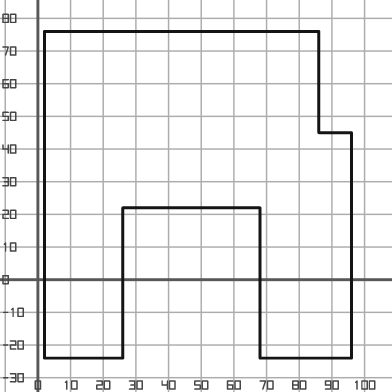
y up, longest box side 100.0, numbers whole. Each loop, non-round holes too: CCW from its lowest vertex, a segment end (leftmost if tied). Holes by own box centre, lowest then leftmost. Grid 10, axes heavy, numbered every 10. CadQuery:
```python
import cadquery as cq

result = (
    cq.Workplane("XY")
    .moveTo(2.0, -24.0)
    .lineTo(26.0, -24.0)
    .lineTo(26.0, 22.0)
    .lineTo(68.0, 22.0)
    .lineTo(68.0, -24.0)
    .lineTo(96.0, -24.0)
    .lineTo(96.0, 45.0)
    .lineTo(86.0, 45.0)
    .lineTo(86.0, 76.0)
    .lineTo(2.0, 76.0)
    .close()
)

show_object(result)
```